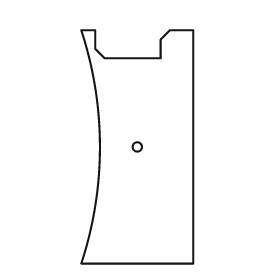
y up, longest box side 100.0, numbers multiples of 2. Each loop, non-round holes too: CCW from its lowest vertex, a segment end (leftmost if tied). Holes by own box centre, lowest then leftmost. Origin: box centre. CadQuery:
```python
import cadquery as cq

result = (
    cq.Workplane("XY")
    .moveTo(-24.0, -50.0)
    .lineTo(24.0, -50.0)
    .lineTo(24.0, 50.0)
    .lineTo(14.0, 50.0)
    .lineTo(10.0, 46.0)
    .lineTo(10.0, 38.0)
    .lineTo(-14.0, 38.0)
    .lineTo(-18.0, 42.0)
    .lineTo(-18.0, 50.0)
    .lineTo(-24.0, 50.0)
    .threePointArc((-16.0, 0.0), (-24.0, -50.0))
    .close()
    .moveTo(0.0, 0.0)
    .circle(2.0)
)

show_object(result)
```